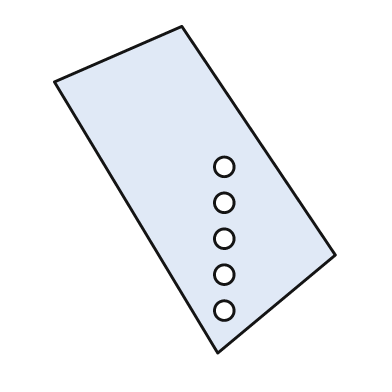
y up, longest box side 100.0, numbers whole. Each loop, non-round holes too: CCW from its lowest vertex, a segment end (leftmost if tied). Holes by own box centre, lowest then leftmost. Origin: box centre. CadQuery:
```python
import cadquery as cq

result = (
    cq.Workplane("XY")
    .moveTo(7.0, -50.0)
    .lineTo(43.0, -20.0)
    .lineTo(-4.0, 50.0)
    .lineTo(-43.0, 33.0)
    .close()
    .moveTo(9.0, -37.0)
    .circle(3.0)
    .moveTo(9.0, -26.0)
    .circle(3.0)
    .moveTo(9.0, -15.0)
    .circle(3.0)
    .moveTo(9.0, -4.0)
    .circle(3.0)
    .moveTo(9.0, 7.0)
    .circle(3.0)
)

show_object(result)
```